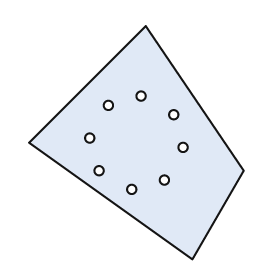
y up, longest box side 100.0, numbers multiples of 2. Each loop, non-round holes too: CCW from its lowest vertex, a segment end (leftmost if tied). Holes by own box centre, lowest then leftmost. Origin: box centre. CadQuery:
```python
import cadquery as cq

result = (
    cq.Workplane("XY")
    .moveTo(24.0, -50.0)
    .lineTo(46.0, -12.0)
    .lineTo(4.0, 50.0)
    .lineTo(-46.0, 0.0)
    .close()
    .moveTo(-2.0, -20.0)
    .circle(2.0)
    .moveTo(12.0, -16.0)
    .circle(2.0)
    .moveTo(-16.0, -12.0)
    .circle(2.0)
    .moveTo(20.0, -2.0)
    .circle(2.0)
    .moveTo(-20.0, 2.0)
    .circle(2.0)
    .moveTo(16.0, 12.0)
    .circle(2.0)
    .moveTo(-12.0, 16.0)
    .circle(2.0)
    .moveTo(2.0, 20.0)
    .circle(2.0)
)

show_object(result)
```